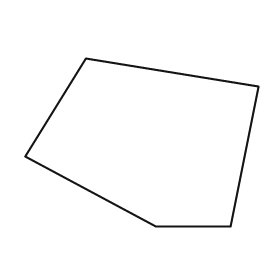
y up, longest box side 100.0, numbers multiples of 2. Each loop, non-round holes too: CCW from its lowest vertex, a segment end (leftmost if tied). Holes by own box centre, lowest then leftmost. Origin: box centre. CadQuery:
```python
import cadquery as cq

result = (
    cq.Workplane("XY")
    .moveTo(6.0, -36.0)
    .lineTo(38.0, -36.0)
    .lineTo(50.0, 24.0)
    .lineTo(-24.0, 36.0)
    .lineTo(-50.0, -6.0)
    .close()
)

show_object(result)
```